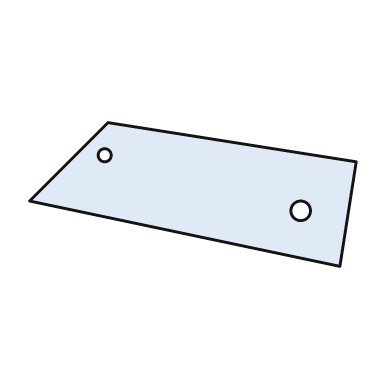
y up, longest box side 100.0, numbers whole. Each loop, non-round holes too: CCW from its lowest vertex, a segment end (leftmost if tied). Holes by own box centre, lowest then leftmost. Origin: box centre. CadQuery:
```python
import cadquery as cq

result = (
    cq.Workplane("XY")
    .moveTo(45.0, -22.0)
    .lineTo(50.0, 10.0)
    .lineTo(-26.0, 22.0)
    .lineTo(-50.0, -2.0)
    .close()
    .moveTo(33.0, -5.0)
    .circle(3.0)
    .moveTo(-27.0, 12.0)
    .circle(2.0)
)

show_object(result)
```